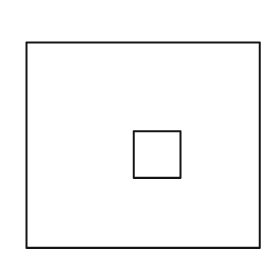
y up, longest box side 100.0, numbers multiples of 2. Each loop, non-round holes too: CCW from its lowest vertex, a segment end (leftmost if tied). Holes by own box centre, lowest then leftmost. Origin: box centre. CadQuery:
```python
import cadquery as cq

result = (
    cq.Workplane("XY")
    .moveTo(-50.0, -44.0)
    .lineTo(50.0, -44.0)
    .lineTo(50.0, 44.0)
    .lineTo(-50.0, 44.0)
    .close()
    .moveTo(-4.0, -14.0)
    .lineTo(16.0, -14.0)
    .lineTo(16.0, 6.0)
    .lineTo(-4.0, 6.0)
    .close()
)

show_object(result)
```